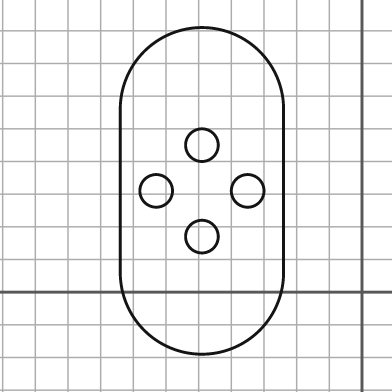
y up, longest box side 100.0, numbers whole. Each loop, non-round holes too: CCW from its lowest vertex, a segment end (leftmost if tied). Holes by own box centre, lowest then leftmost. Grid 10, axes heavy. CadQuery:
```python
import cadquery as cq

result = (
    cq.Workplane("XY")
    .moveTo(-74.0, 6.0)
    .threePointArc((-49.0, -19.0), (-24.0, 6.0))
    .lineTo(-24.0, 56.0)
    .threePointArc((-49.0, 81.0), (-74.0, 56.0))
    .close()
    .moveTo(-49.0, 17.0)
    .circle(5.0)
    .moveTo(-63.0, 31.0)
    .circle(5.0)
    .moveTo(-35.0, 31.0)
    .circle(5.0)
    .moveTo(-49.0, 45.0)
    .circle(5.0)
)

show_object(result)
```